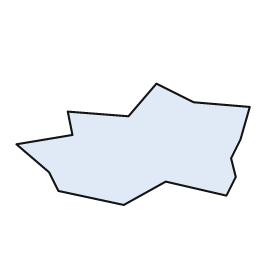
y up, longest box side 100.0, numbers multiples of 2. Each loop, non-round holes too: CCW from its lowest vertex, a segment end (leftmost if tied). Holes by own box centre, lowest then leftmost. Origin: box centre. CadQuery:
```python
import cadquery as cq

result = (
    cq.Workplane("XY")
    .moveTo(-4.0, -26.0)
    .lineTo(14.0, -16.0)
    .lineTo(40.0, -22.0)
    .lineTo(44.0, -14.0)
    .lineTo(42.0, -6.0)
    .lineTo(46.0, 2.0)
    .lineTo(50.0, 16.0)
    .lineTo(26.0, 18.0)
    .lineTo(10.0, 26.0)
    .lineTo(-2.0, 12.0)
    .lineTo(-28.0, 14.0)
    .lineTo(-26.0, 4.0)
    .lineTo(-50.0, 0.0)
    .lineTo(-36.0, -12.0)
    .lineTo(-32.0, -20.0)
    .close()
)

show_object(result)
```